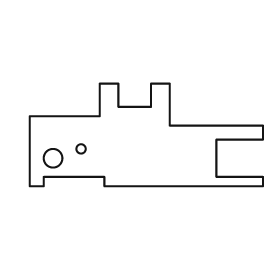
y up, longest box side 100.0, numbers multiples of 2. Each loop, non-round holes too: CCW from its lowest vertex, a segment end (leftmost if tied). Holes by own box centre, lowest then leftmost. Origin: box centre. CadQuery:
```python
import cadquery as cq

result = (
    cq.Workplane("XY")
    .moveTo(-50.0, -22.0)
    .lineTo(-44.0, -22.0)
    .lineTo(-44.0, -18.0)
    .lineTo(-18.0, -18.0)
    .lineTo(-18.0, -22.0)
    .lineTo(50.0, -22.0)
    .lineTo(50.0, -18.0)
    .lineTo(30.0, -18.0)
    .lineTo(30.0, -2.0)
    .lineTo(50.0, -2.0)
    .lineTo(50.0, 4.0)
    .lineTo(10.0, 4.0)
    .lineTo(10.0, 22.0)
    .lineTo(2.0, 22.0)
    .lineTo(2.0, 12.0)
    .lineTo(-12.0, 12.0)
    .lineTo(-12.0, 22.0)
    .lineTo(-20.0, 22.0)
    .lineTo(-20.0, 8.0)
    .lineTo(-50.0, 8.0)
    .close()
    .moveTo(-40.0, -10.0)
    .circle(4.0)
    .moveTo(-28.0, -6.0)
    .circle(2.0)
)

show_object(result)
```